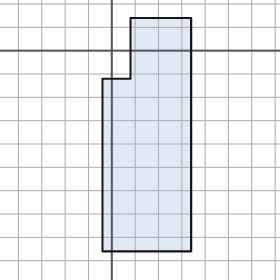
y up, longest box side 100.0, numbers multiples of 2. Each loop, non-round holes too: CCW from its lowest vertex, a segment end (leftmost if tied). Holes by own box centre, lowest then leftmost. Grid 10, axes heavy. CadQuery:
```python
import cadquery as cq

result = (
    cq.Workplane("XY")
    .moveTo(-4.0, -86.0)
    .lineTo(34.0, -86.0)
    .lineTo(34.0, 14.0)
    .lineTo(8.0, 14.0)
    .lineTo(8.0, -12.0)
    .lineTo(-4.0, -12.0)
    .close()
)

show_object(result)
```